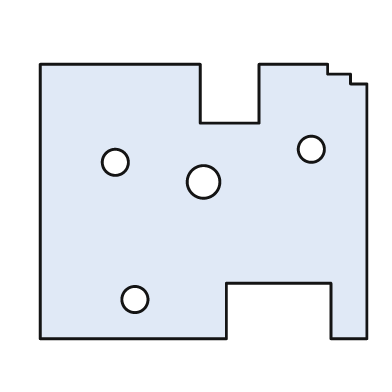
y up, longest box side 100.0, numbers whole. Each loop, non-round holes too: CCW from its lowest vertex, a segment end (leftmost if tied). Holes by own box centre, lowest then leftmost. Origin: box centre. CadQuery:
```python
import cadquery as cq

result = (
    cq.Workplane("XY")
    .moveTo(-50.0, -42.0)
    .lineTo(7.0, -42.0)
    .lineTo(7.0, -25.0)
    .lineTo(39.0, -25.0)
    .lineTo(39.0, -42.0)
    .lineTo(50.0, -42.0)
    .lineTo(50.0, 36.0)
    .lineTo(45.0, 36.0)
    .lineTo(45.0, 39.0)
    .lineTo(38.0, 39.0)
    .lineTo(38.0, 42.0)
    .lineTo(17.0, 42.0)
    .lineTo(17.0, 24.0)
    .lineTo(-1.0, 24.0)
    .lineTo(-1.0, 42.0)
    .lineTo(-50.0, 42.0)
    .close()
    .moveTo(-21.0, -30.0)
    .circle(4.0)
    .moveTo(0.0, 6.0)
    .circle(5.0)
    .moveTo(-27.0, 12.0)
    .circle(4.0)
    .moveTo(33.0, 16.0)
    .circle(4.0)
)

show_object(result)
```